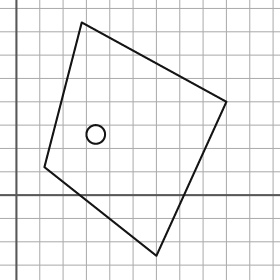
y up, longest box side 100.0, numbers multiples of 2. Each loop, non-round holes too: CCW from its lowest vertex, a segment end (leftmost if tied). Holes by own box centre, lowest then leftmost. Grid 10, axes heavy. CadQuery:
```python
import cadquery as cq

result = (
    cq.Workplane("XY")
    .moveTo(60.0, -26.0)
    .lineTo(90.0, 40.0)
    .lineTo(28.0, 74.0)
    .lineTo(12.0, 12.0)
    .close()
    .moveTo(34.0, 26.0)
    .circle(4.0)
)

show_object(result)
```